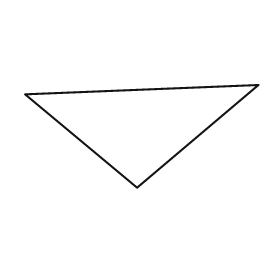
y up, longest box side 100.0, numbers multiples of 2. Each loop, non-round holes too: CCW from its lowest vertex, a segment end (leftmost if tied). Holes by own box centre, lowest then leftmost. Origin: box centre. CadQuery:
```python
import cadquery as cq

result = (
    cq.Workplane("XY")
    .moveTo(-2.0, -22.0)
    .lineTo(50.0, 22.0)
    .lineTo(-50.0, 18.0)
    .close()
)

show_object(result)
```